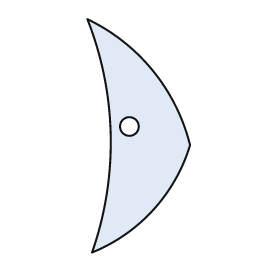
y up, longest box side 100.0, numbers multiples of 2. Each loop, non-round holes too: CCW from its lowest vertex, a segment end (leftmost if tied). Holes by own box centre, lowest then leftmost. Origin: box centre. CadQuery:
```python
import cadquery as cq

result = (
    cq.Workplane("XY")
    .moveTo(-20.0, -50.0)
    .threePointArc((6.0, -32.0), (22.0, -4.0))
    .threePointArc((6.0, 28.0), (-22.0, 50.0))
    .threePointArc((-12.0, 0.0), (-20.0, -50.0))
    .close()
    .moveTo(-4.0, 4.0)
    .circle(4.0)
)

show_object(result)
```